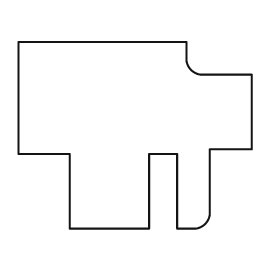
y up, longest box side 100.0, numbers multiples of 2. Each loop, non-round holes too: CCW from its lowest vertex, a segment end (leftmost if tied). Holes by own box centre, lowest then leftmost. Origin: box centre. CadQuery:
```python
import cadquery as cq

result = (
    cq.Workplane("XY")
    .moveTo(-28.0, -40.0)
    .lineTo(6.0, -40.0)
    .lineTo(6.0, -8.0)
    .lineTo(18.0, -8.0)
    .lineTo(18.0, -40.0)
    .lineTo(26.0, -40.0)
    .threePointArc((30.0, -38.0), (32.0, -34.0))
    .lineTo(32.0, -6.0)
    .lineTo(50.0, -6.0)
    .lineTo(50.0, 26.0)
    .lineTo(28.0, 26.0)
    .threePointArc((24.0, 28.0), (22.0, 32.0))
    .lineTo(22.0, 40.0)
    .lineTo(-50.0, 40.0)
    .lineTo(-50.0, -8.0)
    .lineTo(-28.0, -8.0)
    .close()
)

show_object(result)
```